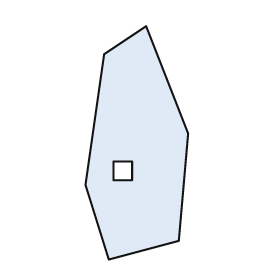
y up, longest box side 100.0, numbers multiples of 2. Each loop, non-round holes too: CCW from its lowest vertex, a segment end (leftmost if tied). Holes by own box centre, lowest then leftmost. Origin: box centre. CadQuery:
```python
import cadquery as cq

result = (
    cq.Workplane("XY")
    .moveTo(-12.0, -50.0)
    .lineTo(18.0, -42.0)
    .lineTo(22.0, 4.0)
    .lineTo(4.0, 50.0)
    .lineTo(-14.0, 38.0)
    .lineTo(-22.0, -18.0)
    .close()
    .moveTo(-10.0, -16.0)
    .lineTo(-2.0, -16.0)
    .lineTo(-2.0, -8.0)
    .lineTo(-10.0, -8.0)
    .close()
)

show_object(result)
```